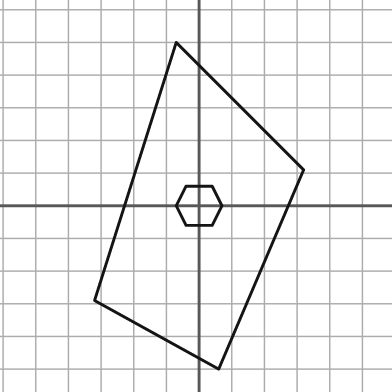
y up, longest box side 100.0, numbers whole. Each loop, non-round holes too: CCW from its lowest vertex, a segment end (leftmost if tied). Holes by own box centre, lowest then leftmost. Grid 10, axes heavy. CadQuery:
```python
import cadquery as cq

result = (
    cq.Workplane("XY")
    .moveTo(6.0, -50.0)
    .lineTo(32.0, 11.0)
    .lineTo(-7.0, 50.0)
    .lineTo(-32.0, -29.0)
    .close()
    .moveTo(-4.0, -6.0)
    .lineTo(4.0, -6.0)
    .lineTo(7.0, 0.0)
    .lineTo(4.0, 6.0)
    .lineTo(-4.0, 6.0)
    .lineTo(-7.0, 0.0)
    .close()
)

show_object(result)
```